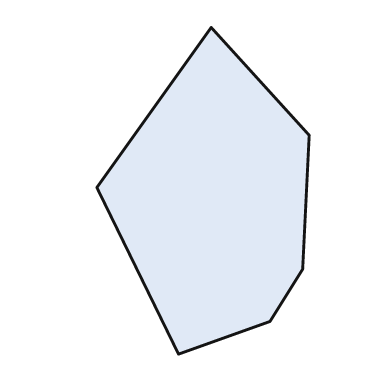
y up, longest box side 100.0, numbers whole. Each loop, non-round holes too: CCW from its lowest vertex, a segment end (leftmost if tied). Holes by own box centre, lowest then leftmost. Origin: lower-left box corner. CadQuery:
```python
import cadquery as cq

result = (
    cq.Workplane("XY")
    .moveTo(25.0, 0.0)
    .lineTo(53.0, 10.0)
    .lineTo(63.0, 26.0)
    .lineTo(65.0, 67.0)
    .lineTo(35.0, 100.0)
    .lineTo(0.0, 51.0)
    .close()
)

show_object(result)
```